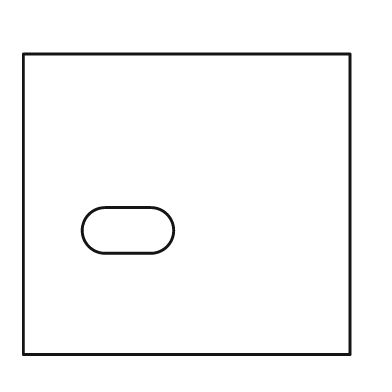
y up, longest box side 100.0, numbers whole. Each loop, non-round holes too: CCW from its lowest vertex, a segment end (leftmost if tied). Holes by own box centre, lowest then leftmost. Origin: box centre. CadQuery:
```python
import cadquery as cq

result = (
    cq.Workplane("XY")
    .moveTo(-50.0, -46.0)
    .lineTo(50.0, -46.0)
    .lineTo(50.0, 46.0)
    .lineTo(-50.0, 46.0)
    .close()
    .moveTo(-25.0, -15.0)
    .lineTo(-11.0, -15.0)
    .threePointArc((-4.0, -8.0), (-11.0, -1.0))
    .lineTo(-25.0, -1.0)
    .threePointArc((-32.0, -8.0), (-25.0, -15.0))
    .close()
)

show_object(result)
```